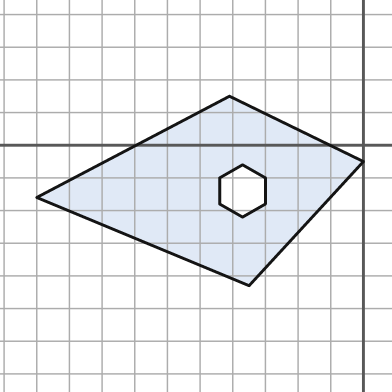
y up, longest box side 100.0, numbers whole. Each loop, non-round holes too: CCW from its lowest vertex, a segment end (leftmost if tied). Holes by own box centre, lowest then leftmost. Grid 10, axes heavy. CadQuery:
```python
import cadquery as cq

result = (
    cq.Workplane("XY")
    .moveTo(-35.0, -43.0)
    .lineTo(0.0, -5.0)
    .lineTo(-41.0, 15.0)
    .lineTo(-100.0, -16.0)
    .close()
    .moveTo(-37.0, -22.0)
    .lineTo(-30.0, -18.0)
    .lineTo(-30.0, -10.0)
    .lineTo(-37.0, -6.0)
    .lineTo(-44.0, -10.0)
    .lineTo(-44.0, -18.0)
    .close()
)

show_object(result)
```